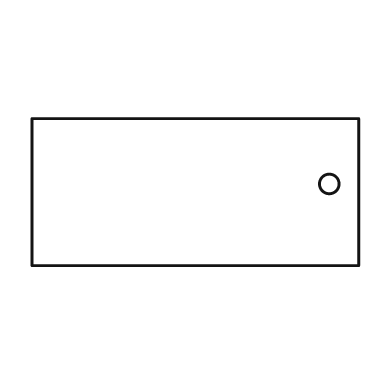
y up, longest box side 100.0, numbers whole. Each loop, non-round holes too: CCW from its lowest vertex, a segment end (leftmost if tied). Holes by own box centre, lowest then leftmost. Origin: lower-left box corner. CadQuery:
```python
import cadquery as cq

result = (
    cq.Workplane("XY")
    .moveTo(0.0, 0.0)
    .lineTo(100.0, 0.0)
    .lineTo(100.0, 45.0)
    .lineTo(0.0, 45.0)
    .close()
    .moveTo(91.0, 25.0)
    .circle(3.0)
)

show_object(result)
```